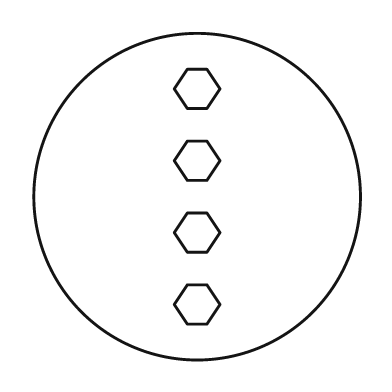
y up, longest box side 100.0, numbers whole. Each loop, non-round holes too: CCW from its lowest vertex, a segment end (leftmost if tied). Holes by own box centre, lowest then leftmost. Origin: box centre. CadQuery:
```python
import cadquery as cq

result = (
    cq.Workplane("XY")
    .moveTo(0.0, 0.0)
    .circle(50.0)
    .moveTo(-3.0, -39.0)
    .lineTo(3.0, -39.0)
    .lineTo(7.0, -33.0)
    .lineTo(3.0, -27.0)
    .lineTo(-3.0, -27.0)
    .lineTo(-7.0, -33.0)
    .close()
    .moveTo(-3.0, -17.0)
    .lineTo(3.0, -17.0)
    .lineTo(7.0, -11.0)
    .lineTo(3.0, -5.0)
    .lineTo(-3.0, -5.0)
    .lineTo(-7.0, -11.0)
    .close()
    .moveTo(-3.0, 5.0)
    .lineTo(3.0, 5.0)
    .lineTo(7.0, 11.0)
    .lineTo(3.0, 17.0)
    .lineTo(-3.0, 17.0)
    .lineTo(-7.0, 11.0)
    .close()
    .moveTo(-3.0, 27.0)
    .lineTo(3.0, 27.0)
    .lineTo(7.0, 33.0)
    .lineTo(3.0, 39.0)
    .lineTo(-3.0, 39.0)
    .lineTo(-7.0, 33.0)
    .close()
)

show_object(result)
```